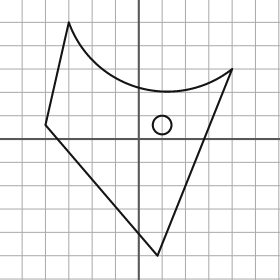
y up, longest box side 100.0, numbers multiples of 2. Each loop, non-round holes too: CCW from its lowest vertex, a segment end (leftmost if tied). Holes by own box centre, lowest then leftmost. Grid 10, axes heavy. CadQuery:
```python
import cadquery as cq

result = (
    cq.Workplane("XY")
    .moveTo(8.0, -50.0)
    .lineTo(40.0, 30.0)
    .threePointArc((0.0, 22.0), (-30.0, 50.0))
    .lineTo(-40.0, 6.0)
    .close()
    .moveTo(10.0, 6.0)
    .circle(4.0)
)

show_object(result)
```